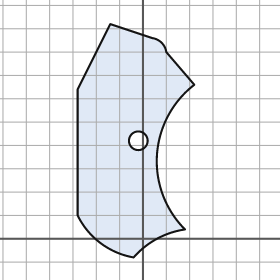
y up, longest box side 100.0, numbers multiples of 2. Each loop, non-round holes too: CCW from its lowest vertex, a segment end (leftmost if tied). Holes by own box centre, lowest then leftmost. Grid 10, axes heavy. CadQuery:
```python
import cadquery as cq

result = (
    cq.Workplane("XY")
    .moveTo(-4.0, -8.0)
    .threePointArc((6.0, 0.0), (18.0, 4.0))
    .threePointArc((6.0, 36.0), (22.0, 66.0))
    .lineTo(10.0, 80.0)
    .threePointArc((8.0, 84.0), (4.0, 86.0))
    .lineTo(-14.0, 92.0)
    .lineTo(-28.0, 64.0)
    .lineTo(-28.0, 10.0)
    .threePointArc((-18.0, -2.0), (-4.0, -8.0))
    .close()
    .moveTo(-2.0, 42.0)
    .circle(4.0)
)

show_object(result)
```